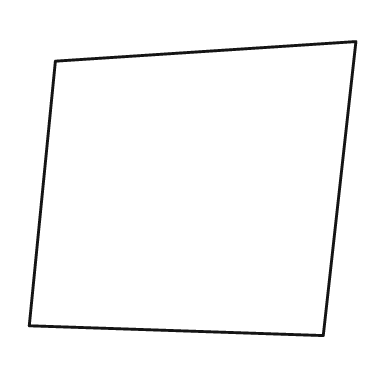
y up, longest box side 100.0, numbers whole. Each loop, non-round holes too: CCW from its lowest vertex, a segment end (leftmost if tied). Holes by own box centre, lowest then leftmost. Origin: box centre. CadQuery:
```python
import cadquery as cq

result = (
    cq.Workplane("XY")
    .moveTo(40.0, -45.0)
    .lineTo(50.0, 45.0)
    .lineTo(-42.0, 39.0)
    .lineTo(-50.0, -42.0)
    .close()
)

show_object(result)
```